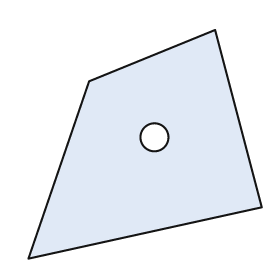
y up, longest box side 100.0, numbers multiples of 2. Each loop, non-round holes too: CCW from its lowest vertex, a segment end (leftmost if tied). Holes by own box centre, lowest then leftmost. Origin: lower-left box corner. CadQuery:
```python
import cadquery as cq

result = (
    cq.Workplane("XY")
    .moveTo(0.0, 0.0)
    .lineTo(100.0, 22.0)
    .lineTo(80.0, 98.0)
    .lineTo(26.0, 76.0)
    .close()
    .moveTo(54.0, 52.0)
    .circle(6.0)
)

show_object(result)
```